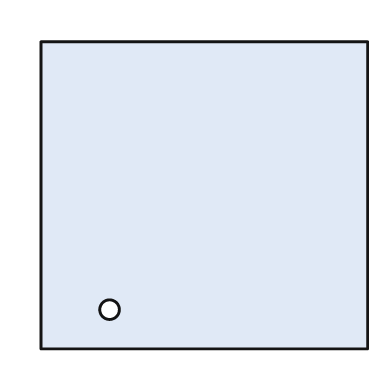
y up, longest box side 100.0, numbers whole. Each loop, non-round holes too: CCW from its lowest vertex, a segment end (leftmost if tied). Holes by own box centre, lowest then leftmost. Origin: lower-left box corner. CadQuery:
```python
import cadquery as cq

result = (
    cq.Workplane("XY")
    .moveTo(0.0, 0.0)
    .lineTo(100.0, 0.0)
    .lineTo(100.0, 94.0)
    .lineTo(0.0, 94.0)
    .close()
    .moveTo(21.0, 12.0)
    .circle(3.0)
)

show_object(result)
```